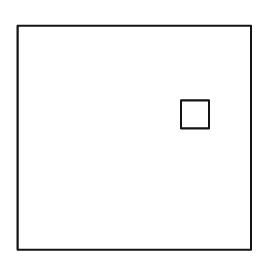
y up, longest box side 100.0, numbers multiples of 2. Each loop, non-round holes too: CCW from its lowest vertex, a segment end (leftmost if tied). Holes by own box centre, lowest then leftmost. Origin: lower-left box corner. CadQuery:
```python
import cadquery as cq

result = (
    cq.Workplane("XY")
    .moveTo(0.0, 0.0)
    .lineTo(100.0, 0.0)
    .lineTo(100.0, 96.0)
    .lineTo(0.0, 96.0)
    .close()
    .moveTo(70.0, 52.0)
    .lineTo(82.0, 52.0)
    .lineTo(82.0, 64.0)
    .lineTo(70.0, 64.0)
    .close()
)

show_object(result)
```